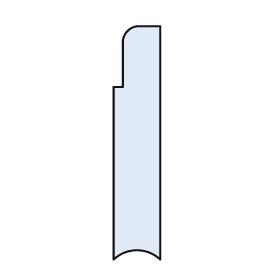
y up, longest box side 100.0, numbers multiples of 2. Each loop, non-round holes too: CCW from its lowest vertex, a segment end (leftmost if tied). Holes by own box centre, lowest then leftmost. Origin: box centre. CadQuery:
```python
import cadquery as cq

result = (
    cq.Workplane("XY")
    .moveTo(-10.0, -50.0)
    .threePointArc((0.0, -46.0), (10.0, -50.0))
    .lineTo(10.0, 50.0)
    .lineTo(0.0, 50.0)
    .threePointArc((-4.0, 48.0), (-6.0, 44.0))
    .lineTo(-6.0, 24.0)
    .lineTo(-10.0, 24.0)
    .close()
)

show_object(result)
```